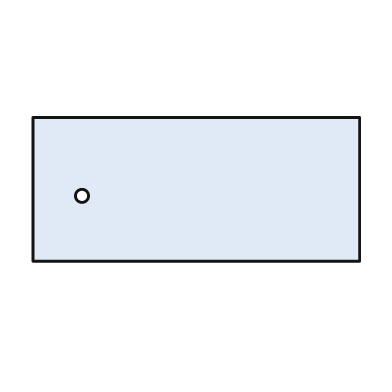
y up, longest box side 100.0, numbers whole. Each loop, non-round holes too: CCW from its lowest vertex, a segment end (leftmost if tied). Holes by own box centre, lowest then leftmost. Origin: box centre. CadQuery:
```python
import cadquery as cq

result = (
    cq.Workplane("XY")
    .moveTo(-50.0, -22.0)
    .lineTo(50.0, -22.0)
    .lineTo(50.0, 22.0)
    .lineTo(-50.0, 22.0)
    .close()
    .moveTo(-35.0, -2.0)
    .circle(2.0)
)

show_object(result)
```